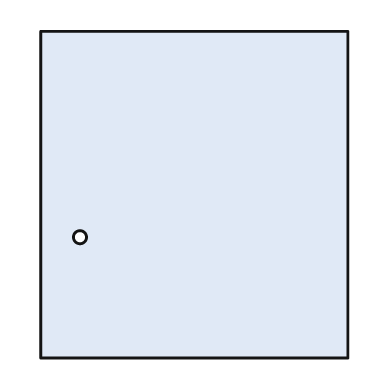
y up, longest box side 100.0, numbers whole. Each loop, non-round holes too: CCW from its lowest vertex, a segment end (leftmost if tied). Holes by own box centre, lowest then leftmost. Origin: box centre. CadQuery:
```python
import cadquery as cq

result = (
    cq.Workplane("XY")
    .moveTo(-47.0, -50.0)
    .lineTo(47.0, -50.0)
    .lineTo(47.0, 50.0)
    .lineTo(-47.0, 50.0)
    .close()
    .moveTo(-35.0, -13.0)
    .circle(2.0)
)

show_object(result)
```